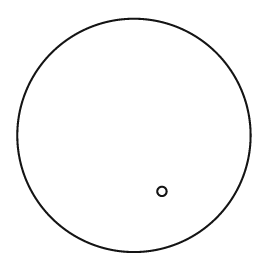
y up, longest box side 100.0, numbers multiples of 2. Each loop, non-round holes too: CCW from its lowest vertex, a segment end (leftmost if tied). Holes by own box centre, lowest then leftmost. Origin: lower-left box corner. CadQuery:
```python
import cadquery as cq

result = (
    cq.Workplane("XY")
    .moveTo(50.0, 50.0)
    .circle(50.0)
    .moveTo(62.0, 26.0)
    .circle(2.0)
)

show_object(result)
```